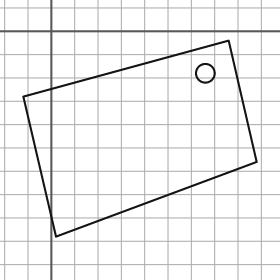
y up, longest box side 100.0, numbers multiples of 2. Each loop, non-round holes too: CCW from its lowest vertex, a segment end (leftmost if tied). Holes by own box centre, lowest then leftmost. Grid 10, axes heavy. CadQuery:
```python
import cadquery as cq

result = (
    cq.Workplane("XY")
    .moveTo(2.0, -88.0)
    .lineTo(88.0, -56.0)
    .lineTo(76.0, -4.0)
    .lineTo(-12.0, -28.0)
    .close()
    .moveTo(66.0, -18.0)
    .circle(4.0)
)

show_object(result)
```